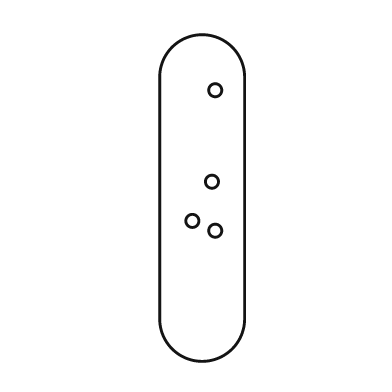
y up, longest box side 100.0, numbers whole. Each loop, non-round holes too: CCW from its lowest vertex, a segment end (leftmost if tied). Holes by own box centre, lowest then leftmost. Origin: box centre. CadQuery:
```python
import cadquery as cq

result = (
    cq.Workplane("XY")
    .moveTo(-13.0, -37.0)
    .threePointArc((0.0, -50.0), (13.0, -37.0))
    .lineTo(13.0, 37.0)
    .threePointArc((0.0, 50.0), (-13.0, 37.0))
    .close()
    .moveTo(4.0, -10.0)
    .circle(2.0)
    .moveTo(-3.0, -7.0)
    .circle(2.0)
    .moveTo(3.0, 5.0)
    .circle(2.0)
    .moveTo(4.0, 33.0)
    .circle(2.0)
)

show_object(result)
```